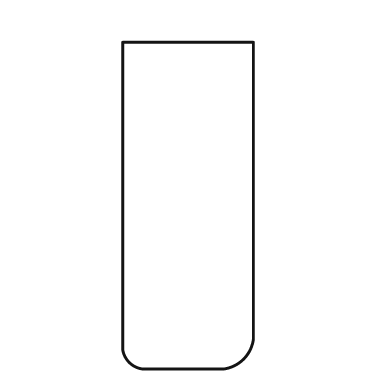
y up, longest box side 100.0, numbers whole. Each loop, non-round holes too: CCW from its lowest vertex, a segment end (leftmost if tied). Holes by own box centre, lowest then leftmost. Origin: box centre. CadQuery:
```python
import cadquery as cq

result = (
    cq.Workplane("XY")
    .moveTo(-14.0, -50.0)
    .lineTo(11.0, -50.0)
    .threePointArc((17.0, -47.0), (20.0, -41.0))
    .lineTo(20.0, 50.0)
    .lineTo(-20.0, 50.0)
    .lineTo(-20.0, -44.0)
    .threePointArc((-18.0, -48.0), (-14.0, -50.0))
    .close()
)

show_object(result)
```